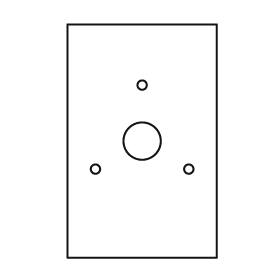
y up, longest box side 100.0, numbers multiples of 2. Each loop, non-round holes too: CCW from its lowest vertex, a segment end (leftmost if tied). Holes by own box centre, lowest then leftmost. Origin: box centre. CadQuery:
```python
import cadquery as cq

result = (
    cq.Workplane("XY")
    .moveTo(-32.0, -50.0)
    .lineTo(32.0, -50.0)
    .lineTo(32.0, 50.0)
    .lineTo(-32.0, 50.0)
    .close()
    .moveTo(-20.0, -12.0)
    .circle(2.0)
    .moveTo(20.0, -12.0)
    .circle(2.0)
    .moveTo(0.0, 0.0)
    .circle(8.0)
    .moveTo(0.0, 24.0)
    .circle(2.0)
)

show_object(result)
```